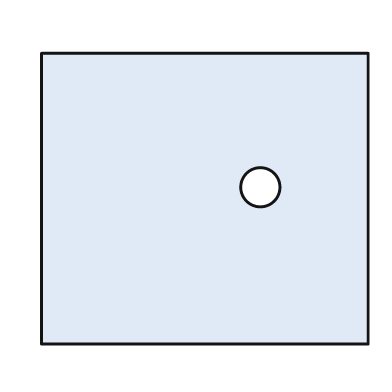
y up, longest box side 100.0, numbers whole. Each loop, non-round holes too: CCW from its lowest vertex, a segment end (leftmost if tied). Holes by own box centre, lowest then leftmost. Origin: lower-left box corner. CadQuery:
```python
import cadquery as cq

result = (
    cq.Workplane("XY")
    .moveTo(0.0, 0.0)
    .lineTo(100.0, 0.0)
    .lineTo(100.0, 89.0)
    .lineTo(0.0, 89.0)
    .close()
    .moveTo(67.0, 48.0)
    .circle(6.0)
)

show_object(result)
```